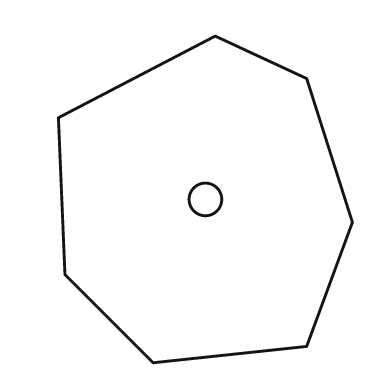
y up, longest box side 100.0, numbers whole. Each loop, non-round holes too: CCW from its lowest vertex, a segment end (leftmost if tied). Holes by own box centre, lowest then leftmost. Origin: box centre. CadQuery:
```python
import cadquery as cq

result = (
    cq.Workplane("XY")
    .moveTo(-16.0, -50.0)
    .lineTo(31.0, -45.0)
    .lineTo(45.0, -7.0)
    .lineTo(31.0, 37.0)
    .lineTo(3.0, 50.0)
    .lineTo(-45.0, 25.0)
    .lineTo(-43.0, -23.0)
    .close()
    .moveTo(0.0, 0.0)
    .circle(5.0)
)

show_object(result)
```